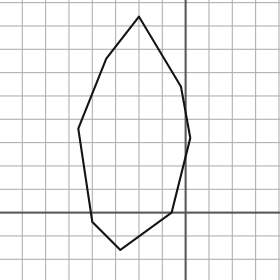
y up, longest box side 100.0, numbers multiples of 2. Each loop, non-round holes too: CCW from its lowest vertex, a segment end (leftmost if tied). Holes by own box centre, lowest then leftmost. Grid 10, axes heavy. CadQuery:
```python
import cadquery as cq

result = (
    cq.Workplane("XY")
    .moveTo(-28.0, -16.0)
    .lineTo(-6.0, 0.0)
    .lineTo(2.0, 32.0)
    .lineTo(-2.0, 54.0)
    .lineTo(-20.0, 84.0)
    .lineTo(-34.0, 66.0)
    .lineTo(-46.0, 36.0)
    .lineTo(-40.0, -4.0)
    .close()
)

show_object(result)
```